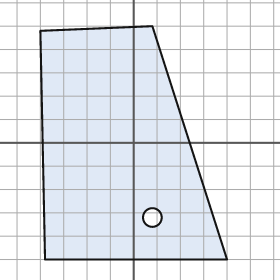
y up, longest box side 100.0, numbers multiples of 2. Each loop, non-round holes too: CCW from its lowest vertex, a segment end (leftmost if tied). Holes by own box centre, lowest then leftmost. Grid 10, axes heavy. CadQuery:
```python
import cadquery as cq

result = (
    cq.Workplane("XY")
    .moveTo(-38.0, -50.0)
    .lineTo(40.0, -50.0)
    .lineTo(8.0, 50.0)
    .lineTo(-40.0, 48.0)
    .close()
    .moveTo(8.0, -32.0)
    .circle(4.0)
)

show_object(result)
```